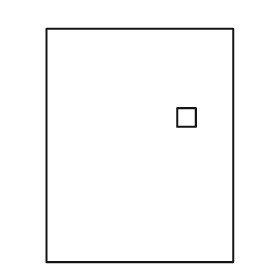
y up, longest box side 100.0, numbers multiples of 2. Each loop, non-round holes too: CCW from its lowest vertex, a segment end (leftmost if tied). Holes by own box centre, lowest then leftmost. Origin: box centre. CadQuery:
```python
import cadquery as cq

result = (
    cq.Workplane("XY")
    .moveTo(-40.0, -50.0)
    .lineTo(40.0, -50.0)
    .lineTo(40.0, 50.0)
    .lineTo(-40.0, 50.0)
    .close()
    .moveTo(16.0, 8.0)
    .lineTo(24.0, 8.0)
    .lineTo(24.0, 16.0)
    .lineTo(16.0, 16.0)
    .close()
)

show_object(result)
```